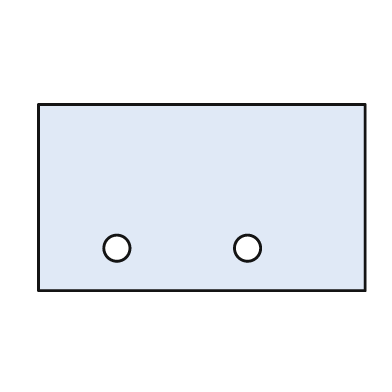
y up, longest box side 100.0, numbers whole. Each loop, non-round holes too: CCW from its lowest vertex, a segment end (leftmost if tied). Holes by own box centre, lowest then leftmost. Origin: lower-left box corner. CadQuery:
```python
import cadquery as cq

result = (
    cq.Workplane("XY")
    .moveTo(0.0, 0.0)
    .lineTo(100.0, 0.0)
    .lineTo(100.0, 57.0)
    .lineTo(0.0, 57.0)
    .close()
    .moveTo(24.0, 13.0)
    .circle(4.0)
    .moveTo(64.0, 13.0)
    .circle(4.0)
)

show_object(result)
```